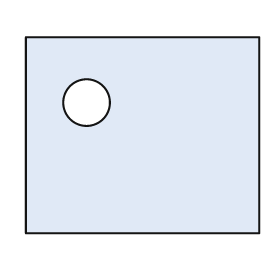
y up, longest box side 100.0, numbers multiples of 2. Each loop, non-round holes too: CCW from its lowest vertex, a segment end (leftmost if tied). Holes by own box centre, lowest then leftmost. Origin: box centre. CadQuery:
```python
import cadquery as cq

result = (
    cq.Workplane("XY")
    .moveTo(-50.0, -42.0)
    .lineTo(50.0, -42.0)
    .lineTo(50.0, 42.0)
    .lineTo(-50.0, 42.0)
    .close()
    .moveTo(-24.0, 14.0)
    .circle(10.0)
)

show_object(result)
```